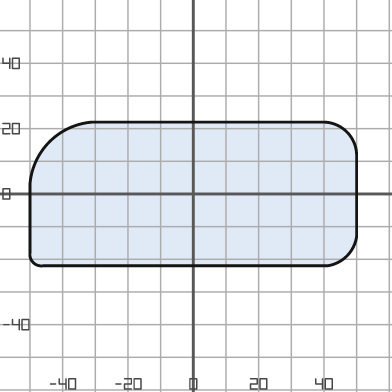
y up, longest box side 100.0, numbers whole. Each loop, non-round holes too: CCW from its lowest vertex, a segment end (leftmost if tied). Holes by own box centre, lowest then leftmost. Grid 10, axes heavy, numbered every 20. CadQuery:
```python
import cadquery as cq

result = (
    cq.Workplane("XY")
    .moveTo(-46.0, -22.0)
    .lineTo(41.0, -22.0)
    .threePointArc((47.0, -19.0), (50.0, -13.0))
    .lineTo(50.0, 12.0)
    .threePointArc((47.0, 19.0), (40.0, 22.0))
    .lineTo(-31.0, 22.0)
    .threePointArc((-44.0, 16.0), (-50.0, 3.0))
    .lineTo(-50.0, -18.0)
    .threePointArc((-49.0, -21.0), (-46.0, -22.0))
    .close()
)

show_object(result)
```